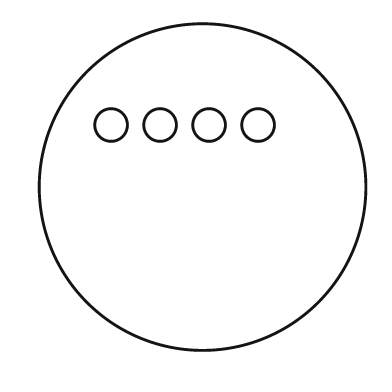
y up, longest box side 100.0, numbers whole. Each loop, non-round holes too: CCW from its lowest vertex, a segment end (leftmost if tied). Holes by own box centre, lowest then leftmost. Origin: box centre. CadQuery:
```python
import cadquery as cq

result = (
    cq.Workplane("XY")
    .moveTo(0.0, 0.0)
    .circle(50.0)
    .moveTo(-28.0, 19.0)
    .circle(5.0)
    .moveTo(-13.0, 19.0)
    .circle(5.0)
    .moveTo(2.0, 19.0)
    .circle(5.0)
    .moveTo(17.0, 19.0)
    .circle(5.0)
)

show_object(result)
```